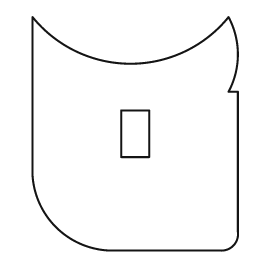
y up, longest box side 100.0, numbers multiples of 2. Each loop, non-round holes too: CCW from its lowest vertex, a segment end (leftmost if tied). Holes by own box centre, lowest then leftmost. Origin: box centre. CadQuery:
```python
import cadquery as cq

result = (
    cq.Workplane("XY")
    .moveTo(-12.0, -50.0)
    .lineTo(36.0, -50.0)
    .threePointArc((42.0, -48.0), (44.0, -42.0))
    .lineTo(44.0, 18.0)
    .lineTo(40.0, 18.0)
    .threePointArc((44.0, 34.0), (40.0, 50.0))
    .threePointArc((-2.0, 30.0), (-44.0, 50.0))
    .lineTo(-44.0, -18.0)
    .threePointArc((-34.0, -40.0), (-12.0, -50.0))
    .close()
    .moveTo(-6.0, -10.0)
    .lineTo(6.0, -10.0)
    .lineTo(6.0, 10.0)
    .lineTo(-6.0, 10.0)
    .close()
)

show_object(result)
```